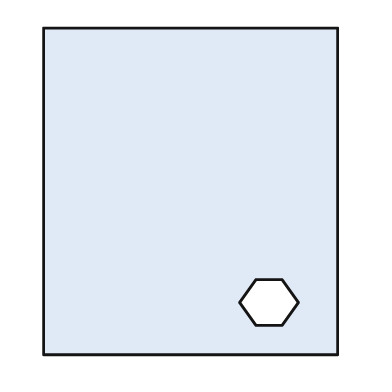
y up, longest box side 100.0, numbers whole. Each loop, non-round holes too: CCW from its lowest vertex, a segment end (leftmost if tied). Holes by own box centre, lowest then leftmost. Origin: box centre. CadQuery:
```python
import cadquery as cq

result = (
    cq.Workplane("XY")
    .moveTo(-45.0, -50.0)
    .lineTo(45.0, -50.0)
    .lineTo(45.0, 50.0)
    .lineTo(-45.0, 50.0)
    .close()
    .moveTo(20.0, -41.0)
    .lineTo(28.0, -41.0)
    .lineTo(33.0, -34.0)
    .lineTo(28.0, -27.0)
    .lineTo(20.0, -27.0)
    .lineTo(15.0, -34.0)
    .close()
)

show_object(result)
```